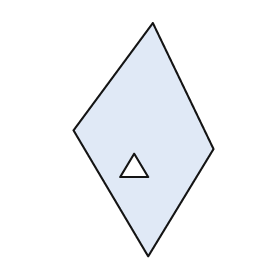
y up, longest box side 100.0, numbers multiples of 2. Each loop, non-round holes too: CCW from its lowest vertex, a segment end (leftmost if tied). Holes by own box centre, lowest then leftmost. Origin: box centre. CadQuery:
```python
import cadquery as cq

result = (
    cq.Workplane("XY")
    .moveTo(2.0, -50.0)
    .lineTo(30.0, -4.0)
    .lineTo(4.0, 50.0)
    .lineTo(-30.0, 4.0)
    .close()
    .moveTo(-10.0, -16.0)
    .lineTo(2.0, -16.0)
    .lineTo(-4.0, -6.0)
    .close()
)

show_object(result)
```